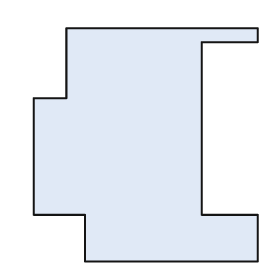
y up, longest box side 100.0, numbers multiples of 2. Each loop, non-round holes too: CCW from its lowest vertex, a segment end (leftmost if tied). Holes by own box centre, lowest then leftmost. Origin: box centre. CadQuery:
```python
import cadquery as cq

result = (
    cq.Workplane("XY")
    .moveTo(-26.0, -50.0)
    .lineTo(48.0, -50.0)
    .lineTo(48.0, -30.0)
    .lineTo(24.0, -30.0)
    .lineTo(24.0, 44.0)
    .lineTo(48.0, 44.0)
    .lineTo(48.0, 50.0)
    .lineTo(-34.0, 50.0)
    .lineTo(-34.0, 20.0)
    .lineTo(-48.0, 20.0)
    .lineTo(-48.0, -30.0)
    .lineTo(-26.0, -30.0)
    .close()
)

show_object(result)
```